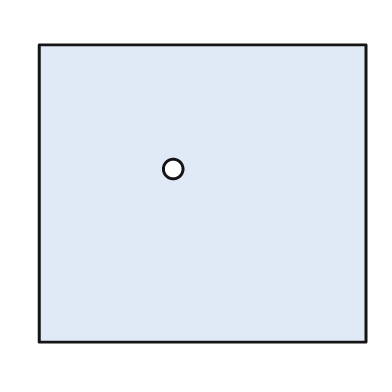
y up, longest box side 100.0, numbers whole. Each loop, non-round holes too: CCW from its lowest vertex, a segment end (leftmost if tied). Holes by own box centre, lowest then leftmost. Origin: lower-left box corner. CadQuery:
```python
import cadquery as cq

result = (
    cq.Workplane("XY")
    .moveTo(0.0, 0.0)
    .lineTo(100.0, 0.0)
    .lineTo(100.0, 91.0)
    .lineTo(0.0, 91.0)
    .close()
    .moveTo(41.0, 53.0)
    .circle(3.0)
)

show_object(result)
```